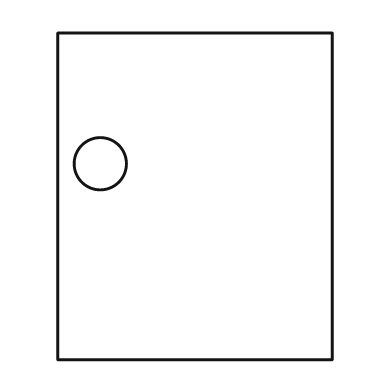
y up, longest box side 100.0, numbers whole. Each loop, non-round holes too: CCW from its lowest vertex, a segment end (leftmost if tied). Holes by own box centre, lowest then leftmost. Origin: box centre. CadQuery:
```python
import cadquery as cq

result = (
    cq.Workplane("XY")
    .moveTo(-42.0, -50.0)
    .lineTo(42.0, -50.0)
    .lineTo(42.0, 50.0)
    .lineTo(-42.0, 50.0)
    .close()
    .moveTo(-29.0, 10.0)
    .circle(8.0)
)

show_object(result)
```